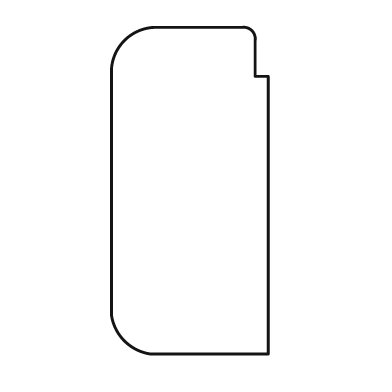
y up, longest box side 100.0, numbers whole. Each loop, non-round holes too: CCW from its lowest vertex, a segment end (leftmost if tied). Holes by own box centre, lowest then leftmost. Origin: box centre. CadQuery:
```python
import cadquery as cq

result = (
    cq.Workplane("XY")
    .moveTo(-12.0, -50.0)
    .lineTo(24.0, -50.0)
    .lineTo(24.0, 35.0)
    .lineTo(20.0, 35.0)
    .lineTo(20.0, 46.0)
    .threePointArc((19.0, 49.0), (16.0, 50.0))
    .lineTo(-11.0, 50.0)
    .threePointArc((-20.0, 46.0), (-24.0, 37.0))
    .lineTo(-24.0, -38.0)
    .threePointArc((-20.0, -46.0), (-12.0, -50.0))
    .close()
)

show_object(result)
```